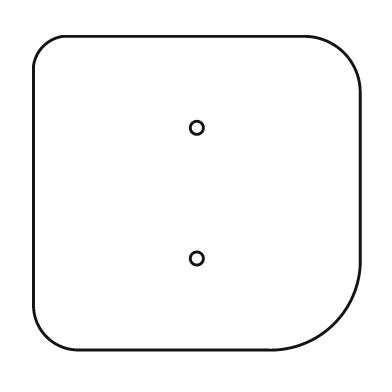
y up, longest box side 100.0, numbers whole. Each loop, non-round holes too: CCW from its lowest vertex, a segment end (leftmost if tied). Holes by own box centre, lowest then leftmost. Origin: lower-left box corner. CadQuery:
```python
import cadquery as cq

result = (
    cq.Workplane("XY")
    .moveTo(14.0, 0.0)
    .lineTo(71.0, 0.0)
    .threePointArc((92.0, 8.0), (100.0, 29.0))
    .lineTo(100.0, 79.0)
    .threePointArc((95.0, 91.0), (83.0, 96.0))
    .lineTo(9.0, 96.0)
    .threePointArc((3.0, 93.0), (0.0, 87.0))
    .lineTo(0.0, 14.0)
    .threePointArc((4.0, 4.0), (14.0, 0.0))
    .close()
    .moveTo(50.0, 28.0)
    .circle(2.0)
    .moveTo(50.0, 68.0)
    .circle(2.0)
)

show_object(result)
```